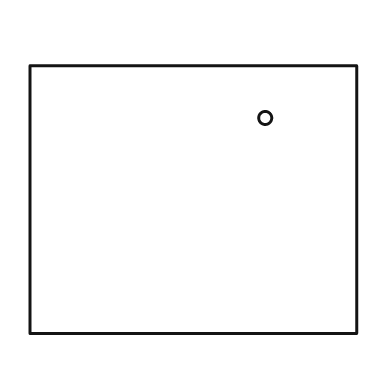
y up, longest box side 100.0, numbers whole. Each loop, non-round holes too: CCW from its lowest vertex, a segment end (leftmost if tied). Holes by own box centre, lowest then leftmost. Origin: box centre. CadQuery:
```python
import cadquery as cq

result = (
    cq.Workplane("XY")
    .moveTo(-50.0, -41.0)
    .lineTo(50.0, -41.0)
    .lineTo(50.0, 41.0)
    .lineTo(-50.0, 41.0)
    .close()
    .moveTo(22.0, 25.0)
    .circle(2.0)
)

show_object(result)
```